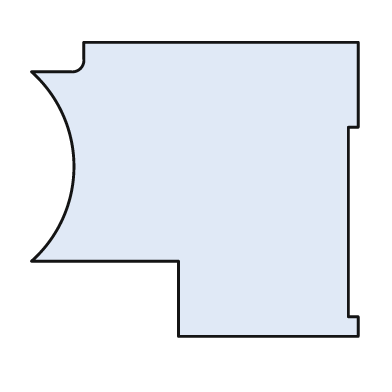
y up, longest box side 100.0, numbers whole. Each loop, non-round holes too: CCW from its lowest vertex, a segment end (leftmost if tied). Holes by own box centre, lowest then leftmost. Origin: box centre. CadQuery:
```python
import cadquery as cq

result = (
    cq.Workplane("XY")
    .moveTo(-5.0, -45.0)
    .lineTo(50.0, -45.0)
    .lineTo(50.0, -39.0)
    .lineTo(47.0, -39.0)
    .lineTo(47.0, 19.0)
    .lineTo(50.0, 19.0)
    .lineTo(50.0, 45.0)
    .lineTo(-34.0, 45.0)
    .lineTo(-34.0, 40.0)
    .threePointArc((-35.0, 37.0), (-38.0, 36.0))
    .lineTo(-50.0, 36.0)
    .threePointArc((-37.0, 7.0), (-50.0, -22.0))
    .lineTo(-5.0, -22.0)
    .close()
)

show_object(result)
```